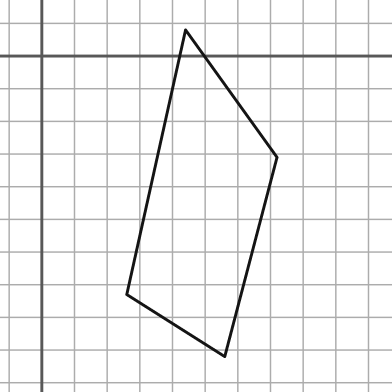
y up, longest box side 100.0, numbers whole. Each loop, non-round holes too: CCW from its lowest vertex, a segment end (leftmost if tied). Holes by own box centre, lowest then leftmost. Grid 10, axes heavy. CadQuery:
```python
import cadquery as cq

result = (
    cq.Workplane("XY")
    .moveTo(56.0, -92.0)
    .lineTo(72.0, -31.0)
    .lineTo(44.0, 8.0)
    .lineTo(26.0, -73.0)
    .close()
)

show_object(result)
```